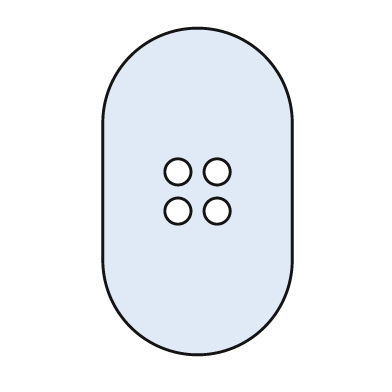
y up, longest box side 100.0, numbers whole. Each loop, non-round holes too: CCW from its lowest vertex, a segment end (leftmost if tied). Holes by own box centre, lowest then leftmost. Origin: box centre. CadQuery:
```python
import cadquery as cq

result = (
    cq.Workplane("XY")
    .moveTo(-29.0, -21.0)
    .threePointArc((0.0, -50.0), (29.0, -21.0))
    .lineTo(29.0, 21.0)
    .threePointArc((0.0, 50.0), (-29.0, 21.0))
    .close()
    .moveTo(-6.0, -6.0)
    .circle(4.0)
    .moveTo(6.0, -6.0)
    .circle(4.0)
    .moveTo(-6.0, 6.0)
    .circle(4.0)
    .moveTo(6.0, 6.0)
    .circle(4.0)
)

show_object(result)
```